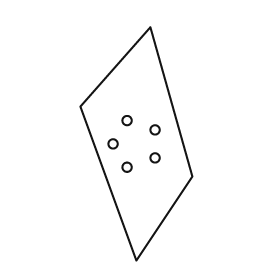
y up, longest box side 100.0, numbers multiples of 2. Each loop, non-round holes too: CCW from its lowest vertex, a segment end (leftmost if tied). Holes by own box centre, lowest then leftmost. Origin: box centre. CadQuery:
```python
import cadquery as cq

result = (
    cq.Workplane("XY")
    .moveTo(0.0, -50.0)
    .lineTo(24.0, -14.0)
    .lineTo(6.0, 50.0)
    .lineTo(-24.0, 16.0)
    .close()
    .moveTo(-4.0, -10.0)
    .circle(2.0)
    .moveTo(8.0, -6.0)
    .circle(2.0)
    .moveTo(-10.0, 0.0)
    .circle(2.0)
    .moveTo(8.0, 6.0)
    .circle(2.0)
    .moveTo(-4.0, 10.0)
    .circle(2.0)
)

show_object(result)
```